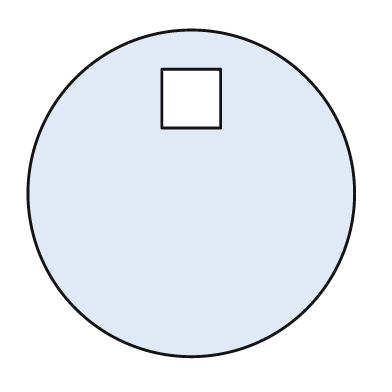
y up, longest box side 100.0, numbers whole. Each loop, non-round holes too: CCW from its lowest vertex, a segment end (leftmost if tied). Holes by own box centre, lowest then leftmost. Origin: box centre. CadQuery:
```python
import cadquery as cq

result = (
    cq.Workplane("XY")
    .moveTo(0.0, 0.0)
    .circle(50.0)
    .moveTo(-9.0, 20.0)
    .lineTo(9.0, 20.0)
    .lineTo(9.0, 38.0)
    .lineTo(-9.0, 38.0)
    .close()
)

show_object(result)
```